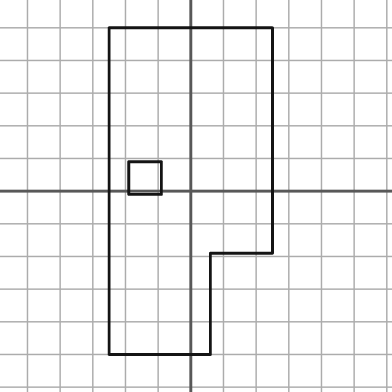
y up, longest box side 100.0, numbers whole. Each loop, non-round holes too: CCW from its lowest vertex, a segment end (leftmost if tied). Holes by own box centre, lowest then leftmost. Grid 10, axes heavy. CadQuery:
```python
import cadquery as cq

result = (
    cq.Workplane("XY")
    .moveTo(-25.0, -50.0)
    .lineTo(6.0, -50.0)
    .lineTo(6.0, -19.0)
    .lineTo(25.0, -19.0)
    .lineTo(25.0, 50.0)
    .lineTo(-25.0, 50.0)
    .close()
    .moveTo(-19.0, -1.0)
    .lineTo(-9.0, -1.0)
    .lineTo(-9.0, 9.0)
    .lineTo(-19.0, 9.0)
    .close()
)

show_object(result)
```